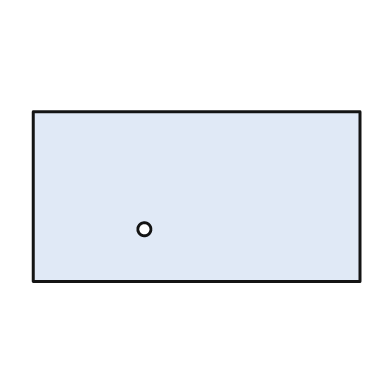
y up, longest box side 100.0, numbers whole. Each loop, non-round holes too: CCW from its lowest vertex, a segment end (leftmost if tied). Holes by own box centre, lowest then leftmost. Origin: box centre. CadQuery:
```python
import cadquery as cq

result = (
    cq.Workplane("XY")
    .moveTo(-50.0, -26.0)
    .lineTo(50.0, -26.0)
    .lineTo(50.0, 26.0)
    .lineTo(-50.0, 26.0)
    .close()
    .moveTo(-16.0, -10.0)
    .circle(2.0)
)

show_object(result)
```